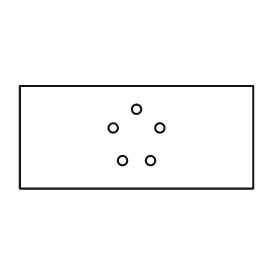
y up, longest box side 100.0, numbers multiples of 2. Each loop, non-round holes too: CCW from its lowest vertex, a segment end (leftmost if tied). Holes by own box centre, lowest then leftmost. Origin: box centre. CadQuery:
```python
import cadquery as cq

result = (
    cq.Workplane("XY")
    .moveTo(-50.0, -22.0)
    .lineTo(50.0, -22.0)
    .lineTo(50.0, 22.0)
    .lineTo(-50.0, 22.0)
    .close()
    .moveTo(-6.0, -10.0)
    .circle(2.0)
    .moveTo(6.0, -10.0)
    .circle(2.0)
    .moveTo(-10.0, 4.0)
    .circle(2.0)
    .moveTo(10.0, 4.0)
    .circle(2.0)
    .moveTo(0.0, 12.0)
    .circle(2.0)
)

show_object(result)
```